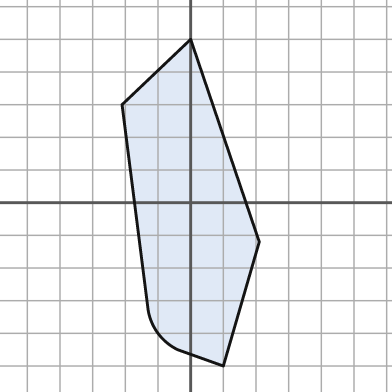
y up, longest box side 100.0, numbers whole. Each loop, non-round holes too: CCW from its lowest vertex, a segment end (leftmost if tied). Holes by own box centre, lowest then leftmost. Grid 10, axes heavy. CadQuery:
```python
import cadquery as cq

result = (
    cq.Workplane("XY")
    .moveTo(10.0, -50.0)
    .lineTo(21.0, -12.0)
    .lineTo(0.0, 50.0)
    .lineTo(-21.0, 30.0)
    .lineTo(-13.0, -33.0)
    .threePointArc((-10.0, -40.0), (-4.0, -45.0))
    .close()
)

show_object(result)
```